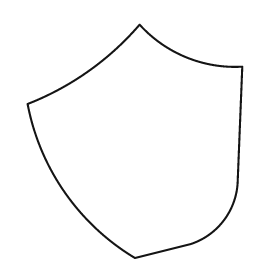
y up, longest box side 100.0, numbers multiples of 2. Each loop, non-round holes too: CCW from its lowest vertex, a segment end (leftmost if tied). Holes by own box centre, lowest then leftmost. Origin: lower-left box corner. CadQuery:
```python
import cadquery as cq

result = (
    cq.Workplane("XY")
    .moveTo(46.0, 0.0)
    .lineTo(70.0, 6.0)
    .threePointArc((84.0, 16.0), (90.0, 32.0))
    .lineTo(92.0, 82.0)
    .threePointArc((68.0, 86.0), (48.0, 100.0))
    .threePointArc((26.0, 80.0), (0.0, 66.0))
    .threePointArc((16.0, 28.0), (46.0, 0.0))
    .close()
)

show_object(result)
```